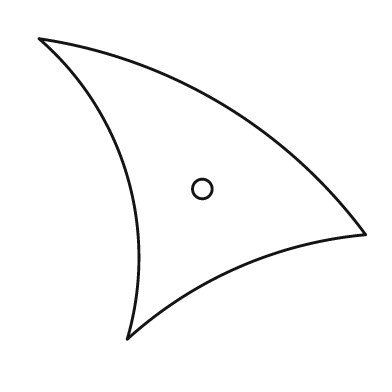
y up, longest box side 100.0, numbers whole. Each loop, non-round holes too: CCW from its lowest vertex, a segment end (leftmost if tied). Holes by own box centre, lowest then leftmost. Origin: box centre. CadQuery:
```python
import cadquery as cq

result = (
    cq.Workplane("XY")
    .moveTo(-23.0, -46.0)
    .threePointArc((11.0, -24.0), (50.0, -14.0))
    .threePointArc((6.0, 26.0), (-50.0, 46.0))
    .threePointArc((-23.0, 4.0), (-23.0, -46.0))
    .close()
    .moveTo(0.0, 0.0)
    .circle(3.0)
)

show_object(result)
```